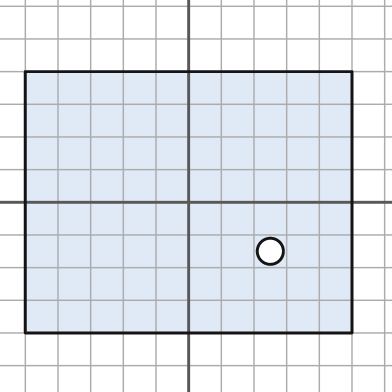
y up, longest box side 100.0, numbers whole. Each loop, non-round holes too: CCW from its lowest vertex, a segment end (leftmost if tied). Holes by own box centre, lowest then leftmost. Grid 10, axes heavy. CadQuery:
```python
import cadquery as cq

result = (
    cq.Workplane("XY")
    .moveTo(-50.0, -40.0)
    .lineTo(50.0, -40.0)
    .lineTo(50.0, 40.0)
    .lineTo(-50.0, 40.0)
    .close()
    .moveTo(25.0, -15.0)
    .circle(4.0)
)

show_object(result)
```